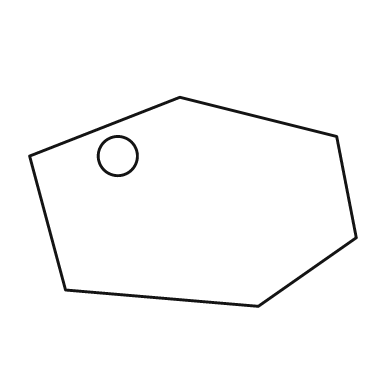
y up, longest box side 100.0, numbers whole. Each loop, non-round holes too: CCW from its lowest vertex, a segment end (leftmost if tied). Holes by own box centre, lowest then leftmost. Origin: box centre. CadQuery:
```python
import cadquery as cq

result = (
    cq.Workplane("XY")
    .moveTo(20.0, -32.0)
    .lineTo(50.0, -11.0)
    .lineTo(44.0, 20.0)
    .lineTo(-4.0, 32.0)
    .lineTo(-50.0, 14.0)
    .lineTo(-39.0, -27.0)
    .close()
    .moveTo(-23.0, 14.0)
    .circle(6.0)
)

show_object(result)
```